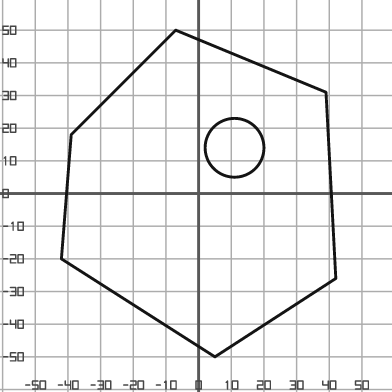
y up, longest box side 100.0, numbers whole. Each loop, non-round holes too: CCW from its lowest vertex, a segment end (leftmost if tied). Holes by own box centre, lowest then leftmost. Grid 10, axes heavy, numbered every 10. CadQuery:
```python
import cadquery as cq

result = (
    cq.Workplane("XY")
    .moveTo(5.0, -50.0)
    .lineTo(42.0, -26.0)
    .lineTo(39.0, 31.0)
    .lineTo(-7.0, 50.0)
    .lineTo(-39.0, 18.0)
    .lineTo(-42.0, -20.0)
    .close()
    .moveTo(11.0, 14.0)
    .circle(9.0)
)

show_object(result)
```